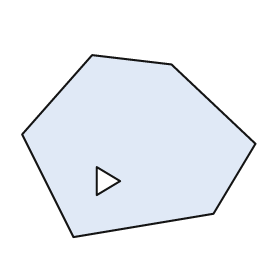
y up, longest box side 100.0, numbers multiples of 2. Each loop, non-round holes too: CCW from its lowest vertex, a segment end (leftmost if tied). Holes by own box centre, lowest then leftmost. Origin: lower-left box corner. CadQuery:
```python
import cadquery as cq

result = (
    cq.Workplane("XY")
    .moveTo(22.0, 0.0)
    .lineTo(82.0, 10.0)
    .lineTo(100.0, 40.0)
    .lineTo(64.0, 74.0)
    .lineTo(30.0, 78.0)
    .lineTo(0.0, 44.0)
    .close()
    .moveTo(32.0, 18.0)
    .lineTo(42.0, 24.0)
    .lineTo(32.0, 30.0)
    .close()
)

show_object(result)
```